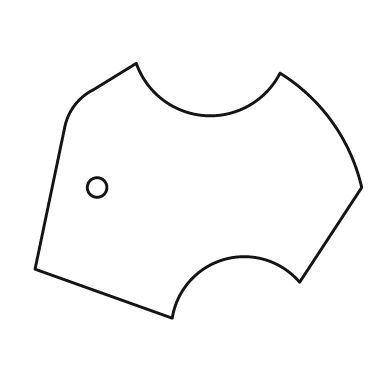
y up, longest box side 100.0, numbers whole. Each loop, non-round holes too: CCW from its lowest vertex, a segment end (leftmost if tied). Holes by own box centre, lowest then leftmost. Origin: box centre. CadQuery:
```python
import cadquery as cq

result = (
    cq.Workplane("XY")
    .moveTo(-8.0, -39.0)
    .threePointArc((8.0, -21.0), (31.0, -28.0))
    .lineTo(50.0, 1.0)
    .threePointArc((41.0, 21.0), (25.0, 36.0))
    .threePointArc((2.0, 23.0), (-19.0, 39.0))
    .lineTo(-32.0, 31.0)
    .threePointArc((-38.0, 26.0), (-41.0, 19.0))
    .lineTo(-50.0, -24.0)
    .close()
    .moveTo(-31.0, 1.0)
    .circle(3.0)
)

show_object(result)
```